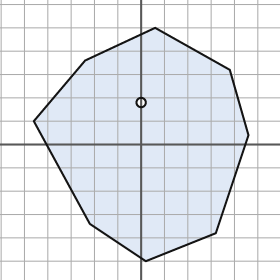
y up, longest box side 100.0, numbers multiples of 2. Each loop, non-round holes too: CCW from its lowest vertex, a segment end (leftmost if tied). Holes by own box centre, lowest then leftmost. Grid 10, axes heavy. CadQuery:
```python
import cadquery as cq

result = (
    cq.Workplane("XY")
    .moveTo(2.0, -50.0)
    .lineTo(32.0, -38.0)
    .lineTo(46.0, 4.0)
    .lineTo(38.0, 32.0)
    .lineTo(6.0, 50.0)
    .lineTo(-24.0, 36.0)
    .lineTo(-46.0, 10.0)
    .lineTo(-22.0, -34.0)
    .close()
    .moveTo(0.0, 18.0)
    .circle(2.0)
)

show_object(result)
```